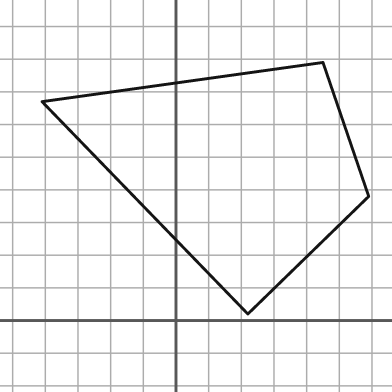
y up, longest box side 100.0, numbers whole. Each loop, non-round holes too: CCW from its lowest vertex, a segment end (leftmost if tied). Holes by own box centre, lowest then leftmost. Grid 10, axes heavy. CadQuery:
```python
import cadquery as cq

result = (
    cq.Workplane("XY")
    .moveTo(22.0, 2.0)
    .lineTo(59.0, 38.0)
    .lineTo(45.0, 79.0)
    .lineTo(-41.0, 67.0)
    .close()
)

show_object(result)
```